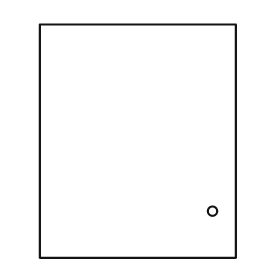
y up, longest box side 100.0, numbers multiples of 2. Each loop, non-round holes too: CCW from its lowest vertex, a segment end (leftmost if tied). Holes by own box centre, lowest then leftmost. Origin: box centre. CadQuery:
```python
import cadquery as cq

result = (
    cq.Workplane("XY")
    .moveTo(-42.0, -50.0)
    .lineTo(42.0, -50.0)
    .lineTo(42.0, 50.0)
    .lineTo(-42.0, 50.0)
    .close()
    .moveTo(32.0, -30.0)
    .circle(2.0)
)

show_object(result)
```